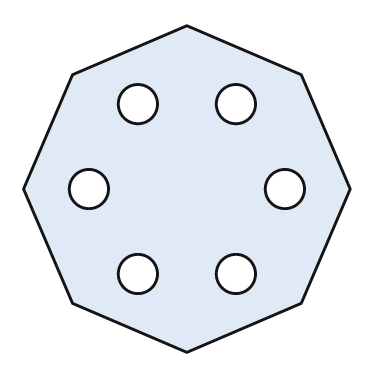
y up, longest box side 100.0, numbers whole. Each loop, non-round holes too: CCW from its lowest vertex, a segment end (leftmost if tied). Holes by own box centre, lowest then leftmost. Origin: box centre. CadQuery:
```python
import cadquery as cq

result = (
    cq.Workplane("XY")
    .moveTo(0.0, -50.0)
    .lineTo(35.0, -35.0)
    .lineTo(50.0, 0.0)
    .lineTo(35.0, 35.0)
    .lineTo(0.0, 50.0)
    .lineTo(-35.0, 35.0)
    .lineTo(-50.0, 0.0)
    .lineTo(-35.0, -35.0)
    .close()
    .moveTo(-15.0, -26.0)
    .circle(6.0)
    .moveTo(15.0, -26.0)
    .circle(6.0)
    .moveTo(-30.0, 0.0)
    .circle(6.0)
    .moveTo(30.0, 0.0)
    .circle(6.0)
    .moveTo(-15.0, 26.0)
    .circle(6.0)
    .moveTo(15.0, 26.0)
    .circle(6.0)
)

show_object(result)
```